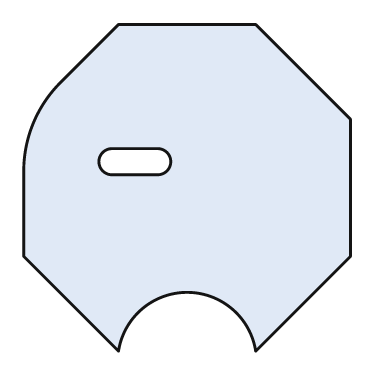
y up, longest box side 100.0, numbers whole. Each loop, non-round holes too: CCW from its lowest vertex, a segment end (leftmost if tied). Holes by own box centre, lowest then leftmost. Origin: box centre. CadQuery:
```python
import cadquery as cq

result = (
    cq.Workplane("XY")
    .moveTo(-21.0, -50.0)
    .threePointArc((0.0, -32.0), (21.0, -50.0))
    .lineTo(50.0, -21.0)
    .lineTo(50.0, 21.0)
    .lineTo(21.0, 50.0)
    .lineTo(-21.0, 50.0)
    .lineTo(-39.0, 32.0)
    .threePointArc((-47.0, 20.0), (-50.0, 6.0))
    .lineTo(-50.0, -21.0)
    .close()
    .moveTo(-23.0, 4.0)
    .lineTo(-9.0, 4.0)
    .threePointArc((-5.0, 8.0), (-9.0, 12.0))
    .lineTo(-23.0, 12.0)
    .threePointArc((-27.0, 8.0), (-23.0, 4.0))
    .close()
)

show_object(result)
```